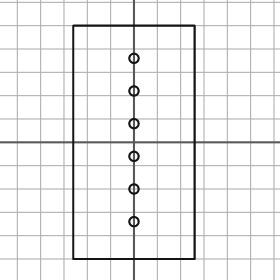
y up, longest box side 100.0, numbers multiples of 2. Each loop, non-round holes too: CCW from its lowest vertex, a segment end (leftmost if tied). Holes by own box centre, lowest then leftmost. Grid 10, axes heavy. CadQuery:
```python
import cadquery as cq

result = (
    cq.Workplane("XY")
    .moveTo(-26.0, -50.0)
    .lineTo(26.0, -50.0)
    .lineTo(26.0, 50.0)
    .lineTo(-26.0, 50.0)
    .close()
    .moveTo(0.0, -34.0)
    .circle(2.0)
    .moveTo(0.0, -20.0)
    .circle(2.0)
    .moveTo(0.0, -6.0)
    .circle(2.0)
    .moveTo(0.0, 8.0)
    .circle(2.0)
    .moveTo(0.0, 22.0)
    .circle(2.0)
    .moveTo(0.0, 36.0)
    .circle(2.0)
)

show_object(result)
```